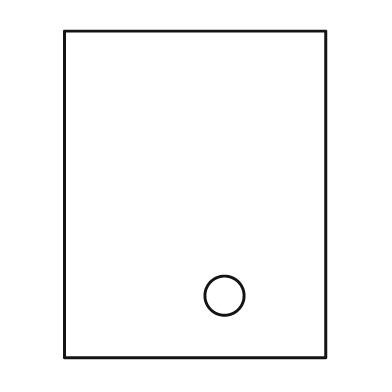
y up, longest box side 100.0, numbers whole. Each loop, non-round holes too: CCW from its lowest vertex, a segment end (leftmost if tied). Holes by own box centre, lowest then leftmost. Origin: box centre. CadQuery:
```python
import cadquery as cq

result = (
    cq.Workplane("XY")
    .moveTo(-40.0, -50.0)
    .lineTo(40.0, -50.0)
    .lineTo(40.0, 50.0)
    .lineTo(-40.0, 50.0)
    .close()
    .moveTo(9.0, -31.0)
    .circle(6.0)
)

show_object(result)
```